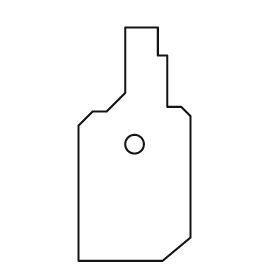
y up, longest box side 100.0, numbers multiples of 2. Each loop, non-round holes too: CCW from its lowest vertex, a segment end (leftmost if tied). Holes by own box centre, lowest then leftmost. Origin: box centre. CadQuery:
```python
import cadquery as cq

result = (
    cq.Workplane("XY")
    .moveTo(-24.0, -50.0)
    .lineTo(12.0, -50.0)
    .lineTo(24.0, -40.0)
    .lineTo(24.0, 12.0)
    .lineTo(20.0, 16.0)
    .lineTo(14.0, 16.0)
    .lineTo(14.0, 38.0)
    .lineTo(10.0, 38.0)
    .lineTo(10.0, 50.0)
    .lineTo(-4.0, 50.0)
    .lineTo(-4.0, 22.0)
    .lineTo(-12.0, 14.0)
    .lineTo(-18.0, 14.0)
    .lineTo(-24.0, 8.0)
    .close()
    .moveTo(0.0, 0.0)
    .circle(4.0)
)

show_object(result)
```